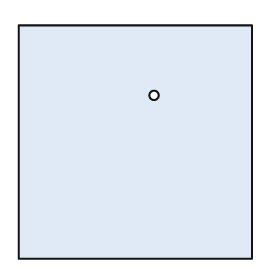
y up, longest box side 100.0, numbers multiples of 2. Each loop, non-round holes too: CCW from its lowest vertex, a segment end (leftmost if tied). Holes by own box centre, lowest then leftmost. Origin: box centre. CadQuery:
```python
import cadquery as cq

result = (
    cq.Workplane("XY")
    .moveTo(-50.0, -50.0)
    .lineTo(50.0, -50.0)
    .lineTo(50.0, 50.0)
    .lineTo(-50.0, 50.0)
    .close()
    .moveTo(8.0, 20.0)
    .circle(2.0)
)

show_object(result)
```